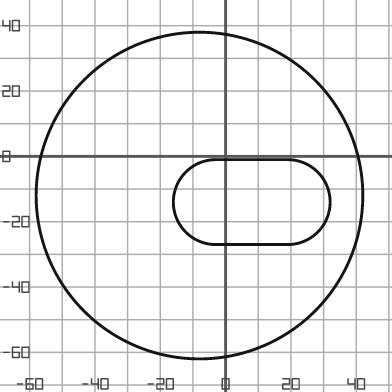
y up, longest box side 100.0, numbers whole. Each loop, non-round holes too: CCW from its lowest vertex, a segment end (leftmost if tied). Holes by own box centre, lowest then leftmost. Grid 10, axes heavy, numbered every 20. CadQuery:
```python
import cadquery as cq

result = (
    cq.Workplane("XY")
    .moveTo(-8.0, -12.0)
    .circle(50.0)
    .moveTo(-3.0, -27.0)
    .lineTo(19.0, -27.0)
    .threePointArc((32.0, -14.0), (19.0, -1.0))
    .lineTo(-3.0, -1.0)
    .threePointArc((-16.0, -14.0), (-3.0, -27.0))
    .close()
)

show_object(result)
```